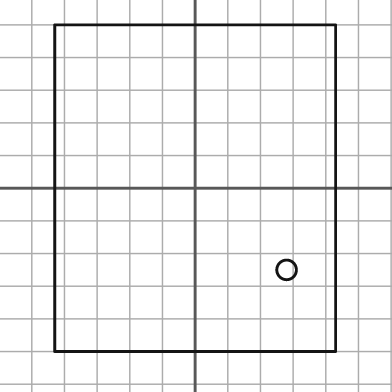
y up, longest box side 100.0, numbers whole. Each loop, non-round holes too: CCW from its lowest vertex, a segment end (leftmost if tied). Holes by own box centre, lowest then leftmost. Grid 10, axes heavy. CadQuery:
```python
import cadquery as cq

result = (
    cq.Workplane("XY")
    .moveTo(-43.0, -50.0)
    .lineTo(43.0, -50.0)
    .lineTo(43.0, 50.0)
    .lineTo(-43.0, 50.0)
    .close()
    .moveTo(28.0, -25.0)
    .circle(3.0)
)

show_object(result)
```